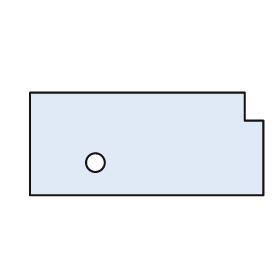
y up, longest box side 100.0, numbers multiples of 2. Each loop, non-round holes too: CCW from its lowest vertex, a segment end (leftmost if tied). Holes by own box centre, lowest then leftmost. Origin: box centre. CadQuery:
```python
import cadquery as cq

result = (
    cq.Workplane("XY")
    .moveTo(-50.0, -22.0)
    .lineTo(50.0, -22.0)
    .lineTo(50.0, 10.0)
    .lineTo(42.0, 10.0)
    .lineTo(42.0, 22.0)
    .lineTo(-50.0, 22.0)
    .close()
    .moveTo(-22.0, -8.0)
    .circle(4.0)
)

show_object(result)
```